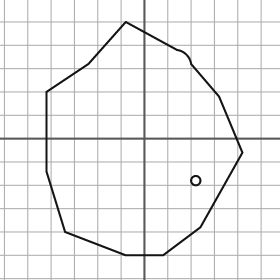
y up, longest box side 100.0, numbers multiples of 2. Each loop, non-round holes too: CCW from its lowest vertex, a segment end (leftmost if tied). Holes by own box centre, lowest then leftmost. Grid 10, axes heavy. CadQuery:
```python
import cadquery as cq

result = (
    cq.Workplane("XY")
    .moveTo(-8.0, -50.0)
    .lineTo(8.0, -50.0)
    .lineTo(24.0, -38.0)
    .lineTo(42.0, -6.0)
    .lineTo(32.0, 18.0)
    .lineTo(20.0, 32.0)
    .threePointArc((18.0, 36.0), (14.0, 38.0))
    .lineTo(-8.0, 50.0)
    .lineTo(-24.0, 32.0)
    .lineTo(-42.0, 20.0)
    .lineTo(-42.0, -14.0)
    .lineTo(-34.0, -40.0)
    .close()
    .moveTo(22.0, -18.0)
    .circle(2.0)
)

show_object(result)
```